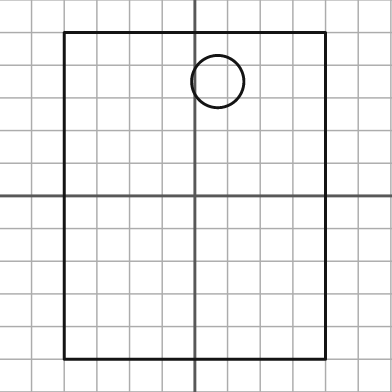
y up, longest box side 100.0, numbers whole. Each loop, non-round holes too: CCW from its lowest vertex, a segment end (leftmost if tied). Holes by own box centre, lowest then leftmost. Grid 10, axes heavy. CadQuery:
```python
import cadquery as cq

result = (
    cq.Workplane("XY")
    .moveTo(-40.0, -50.0)
    .lineTo(40.0, -50.0)
    .lineTo(40.0, 50.0)
    .lineTo(-40.0, 50.0)
    .close()
    .moveTo(7.0, 35.0)
    .circle(8.0)
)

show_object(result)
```